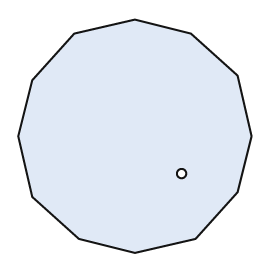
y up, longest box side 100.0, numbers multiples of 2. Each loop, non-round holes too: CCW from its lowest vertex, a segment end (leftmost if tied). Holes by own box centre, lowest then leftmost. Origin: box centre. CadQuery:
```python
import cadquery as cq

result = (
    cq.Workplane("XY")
    .moveTo(0.0, -50.0)
    .lineTo(26.0, -44.0)
    .lineTo(44.0, -24.0)
    .lineTo(50.0, 0.0)
    .lineTo(44.0, 26.0)
    .lineTo(24.0, 44.0)
    .lineTo(0.0, 50.0)
    .lineTo(-26.0, 44.0)
    .lineTo(-44.0, 24.0)
    .lineTo(-50.0, 0.0)
    .lineTo(-44.0, -26.0)
    .lineTo(-24.0, -44.0)
    .close()
    .moveTo(20.0, -16.0)
    .circle(2.0)
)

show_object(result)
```